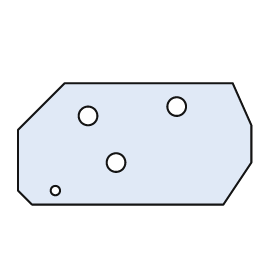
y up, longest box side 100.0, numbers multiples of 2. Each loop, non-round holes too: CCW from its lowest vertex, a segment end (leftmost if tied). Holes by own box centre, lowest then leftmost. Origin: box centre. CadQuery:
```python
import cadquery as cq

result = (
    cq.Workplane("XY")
    .moveTo(-44.0, -26.0)
    .lineTo(38.0, -26.0)
    .lineTo(50.0, -8.0)
    .lineTo(50.0, 8.0)
    .lineTo(42.0, 26.0)
    .lineTo(-30.0, 26.0)
    .lineTo(-50.0, 6.0)
    .lineTo(-50.0, -20.0)
    .close()
    .moveTo(-34.0, -20.0)
    .circle(2.0)
    .moveTo(-8.0, -8.0)
    .circle(4.0)
    .moveTo(-20.0, 12.0)
    .circle(4.0)
    .moveTo(18.0, 16.0)
    .circle(4.0)
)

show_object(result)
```